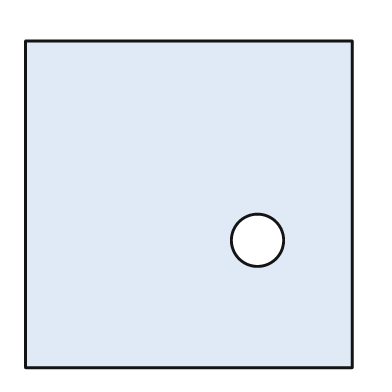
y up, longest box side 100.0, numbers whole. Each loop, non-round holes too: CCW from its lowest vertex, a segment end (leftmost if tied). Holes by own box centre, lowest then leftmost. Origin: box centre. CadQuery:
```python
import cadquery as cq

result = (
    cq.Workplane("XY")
    .moveTo(-50.0, -50.0)
    .lineTo(50.0, -50.0)
    .lineTo(50.0, 50.0)
    .lineTo(-50.0, 50.0)
    .close()
    .moveTo(21.0, -11.0)
    .circle(8.0)
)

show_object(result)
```